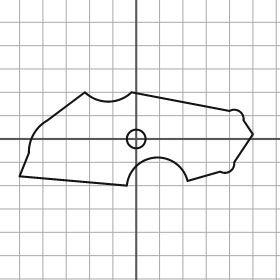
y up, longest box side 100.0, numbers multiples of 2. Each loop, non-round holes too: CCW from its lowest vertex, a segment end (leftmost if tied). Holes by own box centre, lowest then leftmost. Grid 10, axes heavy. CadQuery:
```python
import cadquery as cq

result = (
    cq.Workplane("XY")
    .moveTo(-4.0, -20.0)
    .threePointArc((8.0, -8.0), (22.0, -18.0))
    .lineTo(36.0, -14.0)
    .threePointArc((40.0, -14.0), (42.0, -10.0))
    .lineTo(50.0, 2.0)
    .lineTo(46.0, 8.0)
    .threePointArc((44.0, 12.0), (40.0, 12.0))
    .lineTo(-2.0, 20.0)
    .threePointArc((-12.0, 16.0), (-22.0, 20.0))
    .lineTo(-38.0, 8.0)
    .threePointArc((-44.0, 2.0), (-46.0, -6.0))
    .lineTo(-50.0, -16.0)
    .close()
    .moveTo(0.0, 0.0)
    .circle(4.0)
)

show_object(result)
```